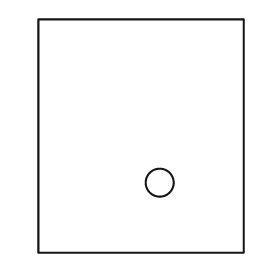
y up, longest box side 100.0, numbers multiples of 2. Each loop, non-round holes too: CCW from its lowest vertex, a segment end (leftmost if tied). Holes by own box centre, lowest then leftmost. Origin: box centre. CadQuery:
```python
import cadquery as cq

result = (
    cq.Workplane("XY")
    .moveTo(-44.0, -50.0)
    .lineTo(44.0, -50.0)
    .lineTo(44.0, 50.0)
    .lineTo(-44.0, 50.0)
    .close()
    .moveTo(8.0, -20.0)
    .circle(6.0)
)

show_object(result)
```